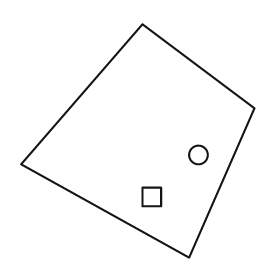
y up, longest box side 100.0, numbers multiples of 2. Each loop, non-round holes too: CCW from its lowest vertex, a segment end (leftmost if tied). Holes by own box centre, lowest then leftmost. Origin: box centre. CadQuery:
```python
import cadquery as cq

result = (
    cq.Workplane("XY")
    .moveTo(22.0, -50.0)
    .lineTo(50.0, 14.0)
    .lineTo(2.0, 50.0)
    .lineTo(-50.0, -10.0)
    .close()
    .moveTo(2.0, -28.0)
    .lineTo(10.0, -28.0)
    .lineTo(10.0, -20.0)
    .lineTo(2.0, -20.0)
    .close()
    .moveTo(26.0, -6.0)
    .circle(4.0)
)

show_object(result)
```